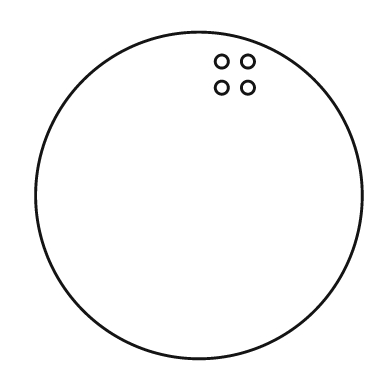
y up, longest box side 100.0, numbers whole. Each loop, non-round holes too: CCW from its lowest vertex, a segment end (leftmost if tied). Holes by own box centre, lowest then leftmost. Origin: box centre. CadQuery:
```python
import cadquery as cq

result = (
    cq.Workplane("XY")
    .moveTo(0.0, 0.0)
    .circle(50.0)
    .moveTo(7.0, 33.0)
    .circle(2.0)
    .moveTo(15.0, 33.0)
    .circle(2.0)
    .moveTo(7.0, 41.0)
    .circle(2.0)
    .moveTo(15.0, 41.0)
    .circle(2.0)
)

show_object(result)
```